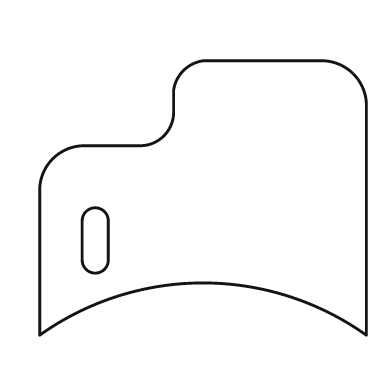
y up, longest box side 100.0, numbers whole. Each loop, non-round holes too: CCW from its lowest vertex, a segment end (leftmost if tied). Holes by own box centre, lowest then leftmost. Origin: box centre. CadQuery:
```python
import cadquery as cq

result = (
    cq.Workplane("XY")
    .moveTo(-50.0, -42.0)
    .threePointArc((0.0, -26.0), (50.0, -42.0))
    .lineTo(50.0, 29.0)
    .threePointArc((46.0, 38.0), (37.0, 42.0))
    .lineTo(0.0, 42.0)
    .threePointArc((-6.0, 39.0), (-9.0, 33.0))
    .lineTo(-9.0, 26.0)
    .threePointArc((-12.0, 19.0), (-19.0, 16.0))
    .lineTo(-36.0, 16.0)
    .threePointArc((-46.0, 12.0), (-50.0, 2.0))
    .close()
    .moveTo(-37.0, -19.0)
    .threePointArc((-33.0, -23.0), (-29.0, -19.0))
    .lineTo(-29.0, -7.0)
    .threePointArc((-33.0, -3.0), (-37.0, -7.0))
    .close()
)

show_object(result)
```